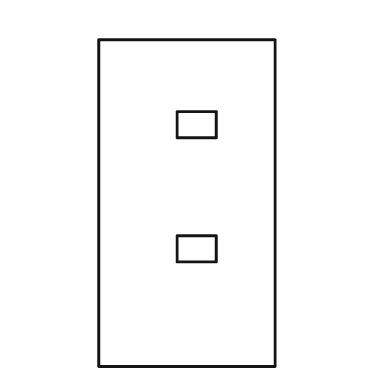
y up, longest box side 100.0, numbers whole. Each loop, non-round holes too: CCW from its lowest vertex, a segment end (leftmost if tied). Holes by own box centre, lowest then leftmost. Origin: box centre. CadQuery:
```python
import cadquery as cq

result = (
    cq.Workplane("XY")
    .moveTo(-27.0, -50.0)
    .lineTo(27.0, -50.0)
    .lineTo(27.0, 50.0)
    .lineTo(-27.0, 50.0)
    .close()
    .moveTo(-3.0, -18.0)
    .lineTo(9.0, -18.0)
    .lineTo(9.0, -10.0)
    .lineTo(-3.0, -10.0)
    .close()
    .moveTo(-3.0, 20.0)
    .lineTo(9.0, 20.0)
    .lineTo(9.0, 28.0)
    .lineTo(-3.0, 28.0)
    .close()
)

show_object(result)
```